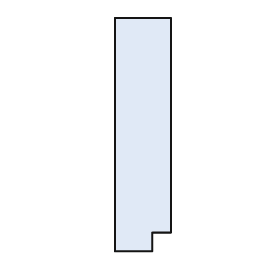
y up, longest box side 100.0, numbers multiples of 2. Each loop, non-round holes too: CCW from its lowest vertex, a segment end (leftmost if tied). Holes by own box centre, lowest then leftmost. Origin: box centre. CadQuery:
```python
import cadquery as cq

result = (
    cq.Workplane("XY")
    .moveTo(-12.0, -50.0)
    .lineTo(4.0, -50.0)
    .lineTo(4.0, -42.0)
    .lineTo(12.0, -42.0)
    .lineTo(12.0, 50.0)
    .lineTo(-12.0, 50.0)
    .close()
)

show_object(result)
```